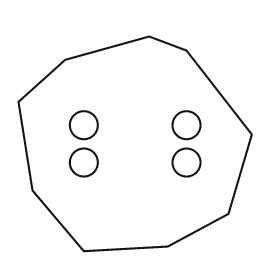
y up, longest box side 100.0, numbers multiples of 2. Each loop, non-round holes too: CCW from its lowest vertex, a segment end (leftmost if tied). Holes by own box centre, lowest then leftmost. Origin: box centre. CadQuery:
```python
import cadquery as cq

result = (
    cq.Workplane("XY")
    .moveTo(-22.0, -46.0)
    .lineTo(14.0, -44.0)
    .lineTo(40.0, -30.0)
    .lineTo(50.0, 4.0)
    .lineTo(22.0, 40.0)
    .lineTo(6.0, 46.0)
    .lineTo(-30.0, 36.0)
    .lineTo(-50.0, 18.0)
    .lineTo(-44.0, -20.0)
    .close()
    .moveTo(-22.0, -8.0)
    .circle(6.0)
    .moveTo(22.0, -8.0)
    .circle(6.0)
    .moveTo(-22.0, 8.0)
    .circle(6.0)
    .moveTo(22.0, 8.0)
    .circle(6.0)
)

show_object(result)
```